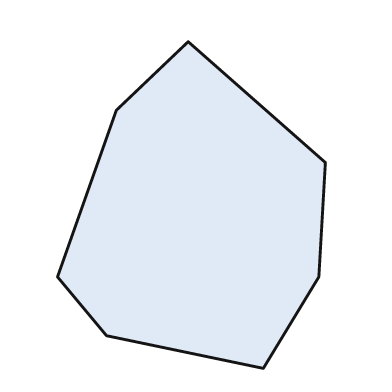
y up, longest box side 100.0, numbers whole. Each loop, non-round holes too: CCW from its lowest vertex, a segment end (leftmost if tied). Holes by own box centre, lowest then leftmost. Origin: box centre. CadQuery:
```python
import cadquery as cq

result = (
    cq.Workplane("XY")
    .moveTo(22.0, -50.0)
    .lineTo(39.0, -22.0)
    .lineTo(41.0, 13.0)
    .lineTo(-1.0, 50.0)
    .lineTo(-23.0, 29.0)
    .lineTo(-41.0, -22.0)
    .lineTo(-26.0, -40.0)
    .close()
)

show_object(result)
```